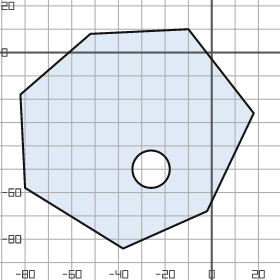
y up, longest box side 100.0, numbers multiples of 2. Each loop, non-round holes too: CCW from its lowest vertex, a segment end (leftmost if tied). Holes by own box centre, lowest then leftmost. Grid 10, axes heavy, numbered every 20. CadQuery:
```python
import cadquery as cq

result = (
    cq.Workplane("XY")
    .moveTo(-38.0, -84.0)
    .lineTo(-2.0, -68.0)
    .lineTo(18.0, -26.0)
    .lineTo(-10.0, 10.0)
    .lineTo(-52.0, 8.0)
    .lineTo(-82.0, -18.0)
    .lineTo(-80.0, -58.0)
    .close()
    .moveTo(-26.0, -50.0)
    .circle(8.0)
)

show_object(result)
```